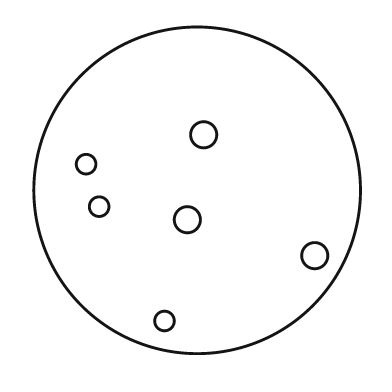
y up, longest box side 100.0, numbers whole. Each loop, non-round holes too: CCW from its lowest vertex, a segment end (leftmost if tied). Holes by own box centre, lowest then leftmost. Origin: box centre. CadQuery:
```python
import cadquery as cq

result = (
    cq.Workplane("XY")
    .moveTo(0.0, 0.0)
    .circle(50.0)
    .moveTo(-10.0, -40.0)
    .circle(3.0)
    .moveTo(36.0, -20.0)
    .circle(4.0)
    .moveTo(-3.0, -9.0)
    .circle(4.0)
    .moveTo(-30.0, -5.0)
    .circle(3.0)
    .moveTo(-34.0, 8.0)
    .circle(3.0)
    .moveTo(2.0, 17.0)
    .circle(4.0)
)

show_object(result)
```